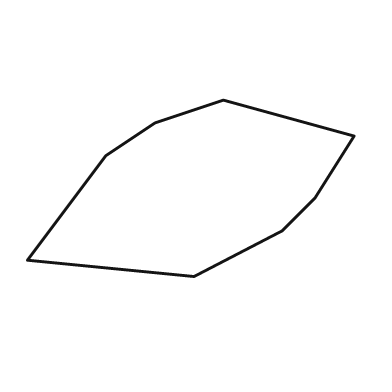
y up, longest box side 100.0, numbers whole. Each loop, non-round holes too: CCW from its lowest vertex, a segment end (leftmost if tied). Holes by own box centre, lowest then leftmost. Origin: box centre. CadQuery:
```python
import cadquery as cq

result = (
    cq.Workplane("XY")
    .moveTo(1.0, -27.0)
    .lineTo(28.0, -13.0)
    .lineTo(38.0, -3.0)
    .lineTo(50.0, 16.0)
    .lineTo(10.0, 27.0)
    .lineTo(-11.0, 20.0)
    .lineTo(-26.0, 10.0)
    .lineTo(-50.0, -22.0)
    .close()
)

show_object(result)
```